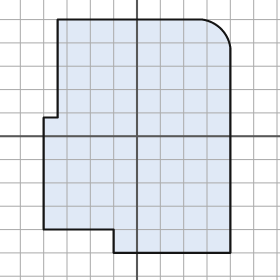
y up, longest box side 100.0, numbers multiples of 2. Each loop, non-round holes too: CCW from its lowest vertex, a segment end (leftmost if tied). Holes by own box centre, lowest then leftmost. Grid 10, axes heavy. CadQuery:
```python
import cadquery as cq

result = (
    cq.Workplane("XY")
    .moveTo(-10.0, -50.0)
    .lineTo(40.0, -50.0)
    .lineTo(40.0, 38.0)
    .threePointArc((36.0, 46.0), (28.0, 50.0))
    .lineTo(-34.0, 50.0)
    .lineTo(-34.0, 8.0)
    .lineTo(-40.0, 8.0)
    .lineTo(-40.0, -40.0)
    .lineTo(-10.0, -40.0)
    .close()
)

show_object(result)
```